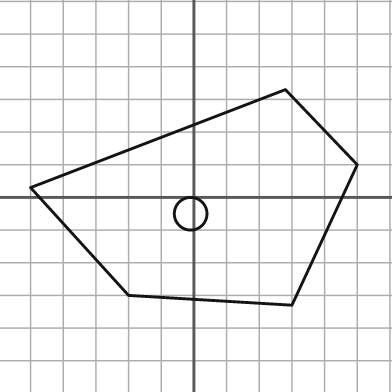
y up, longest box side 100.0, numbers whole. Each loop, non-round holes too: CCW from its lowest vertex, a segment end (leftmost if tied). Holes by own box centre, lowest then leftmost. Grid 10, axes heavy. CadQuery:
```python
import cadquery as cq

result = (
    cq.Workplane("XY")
    .moveTo(30.0, -33.0)
    .lineTo(50.0, 10.0)
    .lineTo(28.0, 33.0)
    .lineTo(-50.0, 3.0)
    .lineTo(-20.0, -30.0)
    .close()
    .moveTo(-1.0, -5.0)
    .circle(5.0)
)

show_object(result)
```